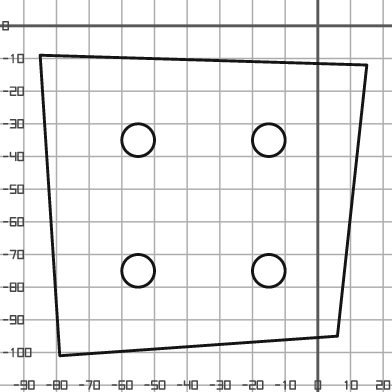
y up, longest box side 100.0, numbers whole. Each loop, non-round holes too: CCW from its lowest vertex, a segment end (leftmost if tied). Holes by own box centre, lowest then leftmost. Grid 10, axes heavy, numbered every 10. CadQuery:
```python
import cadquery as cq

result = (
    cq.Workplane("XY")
    .moveTo(-79.0, -101.0)
    .lineTo(6.0, -95.0)
    .lineTo(15.0, -12.0)
    .lineTo(-85.0, -9.0)
    .close()
    .moveTo(-55.0, -75.0)
    .circle(5.0)
    .moveTo(-15.0, -75.0)
    .circle(5.0)
    .moveTo(-55.0, -35.0)
    .circle(5.0)
    .moveTo(-15.0, -35.0)
    .circle(5.0)
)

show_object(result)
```